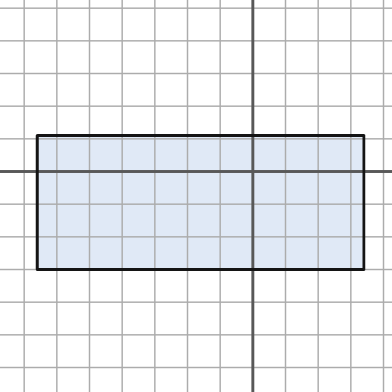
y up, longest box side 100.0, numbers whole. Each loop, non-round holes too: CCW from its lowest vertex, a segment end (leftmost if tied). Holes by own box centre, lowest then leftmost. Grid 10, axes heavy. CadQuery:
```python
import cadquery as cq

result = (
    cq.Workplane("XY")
    .moveTo(-66.0, -30.0)
    .lineTo(34.0, -30.0)
    .lineTo(34.0, 11.0)
    .lineTo(-66.0, 11.0)
    .close()
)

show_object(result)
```